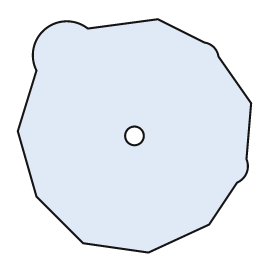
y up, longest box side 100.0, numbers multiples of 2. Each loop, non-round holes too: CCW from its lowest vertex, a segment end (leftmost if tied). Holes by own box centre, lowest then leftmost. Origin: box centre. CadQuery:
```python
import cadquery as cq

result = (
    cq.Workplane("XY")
    .moveTo(6.0, -50.0)
    .lineTo(32.0, -38.0)
    .lineTo(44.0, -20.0)
    .threePointArc((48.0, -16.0), (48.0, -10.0))
    .lineTo(50.0, 14.0)
    .lineTo(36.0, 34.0)
    .threePointArc((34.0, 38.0), (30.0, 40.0))
    .lineTo(10.0, 50.0)
    .lineTo(-20.0, 46.0)
    .threePointArc((-38.0, 46.0), (-42.0, 28.0))
    .lineTo(-50.0, 2.0)
    .lineTo(-42.0, -26.0)
    .lineTo(-22.0, -46.0)
    .close()
    .moveTo(0.0, 0.0)
    .circle(4.0)
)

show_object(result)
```